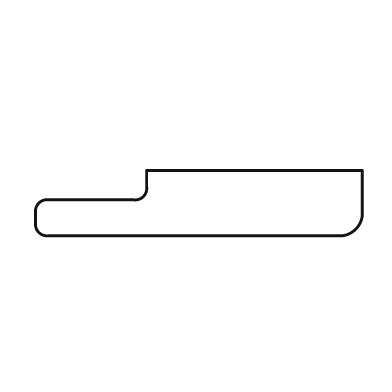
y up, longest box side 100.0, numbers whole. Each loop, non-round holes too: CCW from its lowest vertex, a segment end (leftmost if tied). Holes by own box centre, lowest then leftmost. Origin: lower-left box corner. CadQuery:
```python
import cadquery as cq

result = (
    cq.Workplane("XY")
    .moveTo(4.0, 0.0)
    .lineTo(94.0, 0.0)
    .threePointArc((98.0, 2.0), (100.0, 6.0))
    .lineTo(100.0, 20.0)
    .lineTo(34.0, 20.0)
    .lineTo(34.0, 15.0)
    .threePointArc((33.0, 12.0), (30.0, 11.0))
    .lineTo(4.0, 11.0)
    .threePointArc((1.0, 10.0), (0.0, 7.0))
    .lineTo(0.0, 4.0)
    .threePointArc((1.0, 1.0), (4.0, 0.0))
    .close()
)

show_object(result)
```